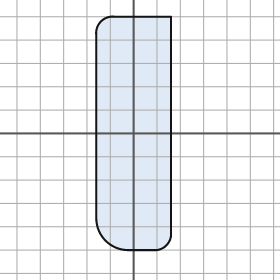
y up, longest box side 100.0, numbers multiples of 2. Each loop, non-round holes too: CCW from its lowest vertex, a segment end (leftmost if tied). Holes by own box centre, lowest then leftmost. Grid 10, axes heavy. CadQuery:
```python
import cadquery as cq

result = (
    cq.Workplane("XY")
    .moveTo(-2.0, -50.0)
    .lineTo(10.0, -50.0)
    .threePointArc((14.0, -48.0), (16.0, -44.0))
    .lineTo(16.0, 50.0)
    .lineTo(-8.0, 50.0)
    .threePointArc((-14.0, 48.0), (-16.0, 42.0))
    .lineTo(-16.0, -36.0)
    .threePointArc((-12.0, -46.0), (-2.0, -50.0))
    .close()
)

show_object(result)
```